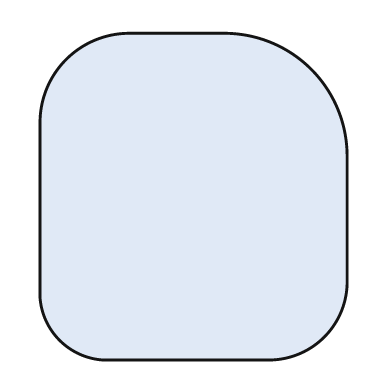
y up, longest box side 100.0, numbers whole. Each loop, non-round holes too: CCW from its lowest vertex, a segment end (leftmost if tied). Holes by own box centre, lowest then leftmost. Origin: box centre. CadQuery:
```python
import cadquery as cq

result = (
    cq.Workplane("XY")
    .moveTo(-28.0, -50.0)
    .lineTo(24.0, -50.0)
    .threePointArc((40.0, -43.0), (47.0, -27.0))
    .lineTo(47.0, 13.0)
    .threePointArc((36.0, 39.0), (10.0, 50.0))
    .lineTo(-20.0, 50.0)
    .threePointArc((-39.0, 42.0), (-47.0, 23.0))
    .lineTo(-47.0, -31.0)
    .threePointArc((-41.0, -44.0), (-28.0, -50.0))
    .close()
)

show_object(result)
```